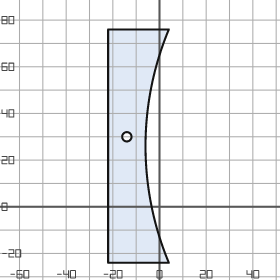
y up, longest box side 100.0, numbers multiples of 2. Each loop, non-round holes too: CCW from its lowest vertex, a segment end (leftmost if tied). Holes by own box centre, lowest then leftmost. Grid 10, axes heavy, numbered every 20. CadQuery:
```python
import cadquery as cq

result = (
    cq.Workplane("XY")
    .moveTo(-22.0, -24.0)
    .lineTo(4.0, -24.0)
    .threePointArc((-6.0, 26.0), (4.0, 76.0))
    .lineTo(-22.0, 76.0)
    .close()
    .moveTo(-14.0, 30.0)
    .circle(2.0)
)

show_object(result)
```